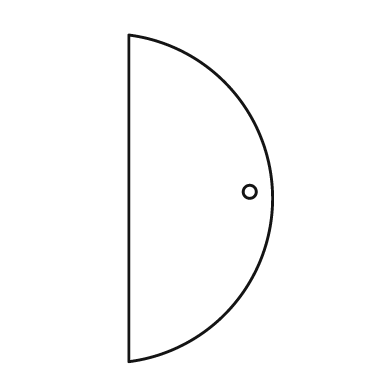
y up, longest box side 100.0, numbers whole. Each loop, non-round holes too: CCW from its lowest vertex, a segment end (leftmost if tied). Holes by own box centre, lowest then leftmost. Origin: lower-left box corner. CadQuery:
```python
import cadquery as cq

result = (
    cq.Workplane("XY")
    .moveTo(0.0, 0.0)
    .threePointArc((44.0, 50.0), (0.0, 100.0))
    .close()
    .moveTo(37.0, 52.0)
    .circle(2.0)
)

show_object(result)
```